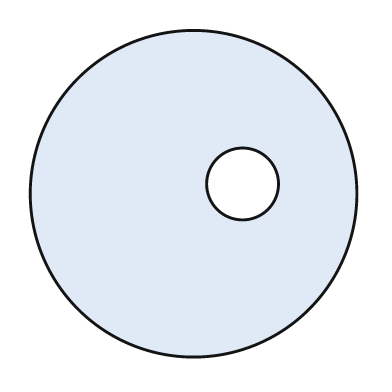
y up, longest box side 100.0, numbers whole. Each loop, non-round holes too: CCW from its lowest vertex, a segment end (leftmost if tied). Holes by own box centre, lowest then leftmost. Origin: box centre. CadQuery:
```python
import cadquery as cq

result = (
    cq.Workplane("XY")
    .moveTo(0.0, 0.0)
    .circle(50.0)
    .moveTo(15.0, 3.0)
    .circle(11.0)
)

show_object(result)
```